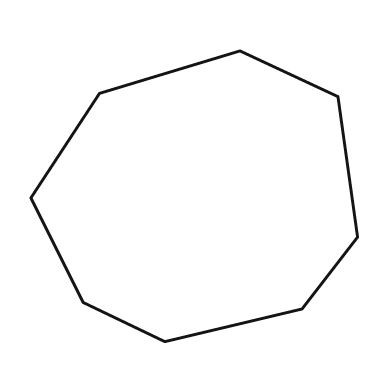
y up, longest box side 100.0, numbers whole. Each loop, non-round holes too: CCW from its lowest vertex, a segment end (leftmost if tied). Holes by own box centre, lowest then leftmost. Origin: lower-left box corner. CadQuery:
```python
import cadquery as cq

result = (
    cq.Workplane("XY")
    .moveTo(41.0, 0.0)
    .lineTo(83.0, 10.0)
    .lineTo(100.0, 32.0)
    .lineTo(94.0, 75.0)
    .lineTo(64.0, 89.0)
    .lineTo(21.0, 76.0)
    .lineTo(0.0, 44.0)
    .lineTo(16.0, 12.0)
    .close()
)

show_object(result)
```